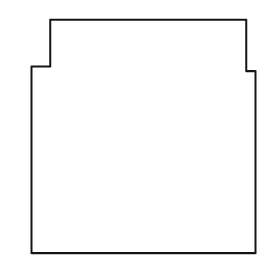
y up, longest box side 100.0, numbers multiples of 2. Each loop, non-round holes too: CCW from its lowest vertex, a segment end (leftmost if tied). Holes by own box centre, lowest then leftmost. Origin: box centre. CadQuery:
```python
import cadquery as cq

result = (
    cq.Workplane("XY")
    .moveTo(-48.0, -50.0)
    .lineTo(48.0, -50.0)
    .lineTo(48.0, 28.0)
    .lineTo(44.0, 28.0)
    .lineTo(44.0, 50.0)
    .lineTo(-40.0, 50.0)
    .lineTo(-40.0, 30.0)
    .lineTo(-48.0, 30.0)
    .close()
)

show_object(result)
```